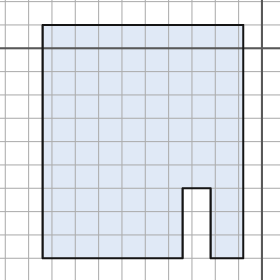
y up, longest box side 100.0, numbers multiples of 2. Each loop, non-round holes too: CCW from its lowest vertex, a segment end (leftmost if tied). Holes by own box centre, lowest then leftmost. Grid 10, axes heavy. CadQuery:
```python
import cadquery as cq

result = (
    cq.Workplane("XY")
    .moveTo(-94.0, -90.0)
    .lineTo(-34.0, -90.0)
    .lineTo(-34.0, -60.0)
    .lineTo(-22.0, -60.0)
    .lineTo(-22.0, -90.0)
    .lineTo(-8.0, -90.0)
    .lineTo(-8.0, 10.0)
    .lineTo(-94.0, 10.0)
    .close()
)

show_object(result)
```